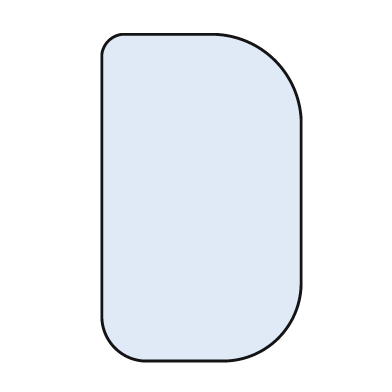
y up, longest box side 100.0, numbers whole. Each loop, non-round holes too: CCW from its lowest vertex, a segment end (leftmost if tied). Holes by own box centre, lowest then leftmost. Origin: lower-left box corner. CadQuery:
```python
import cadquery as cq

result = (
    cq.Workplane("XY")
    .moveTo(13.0, 0.0)
    .lineTo(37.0, 0.0)
    .threePointArc((54.0, 7.0), (61.0, 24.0))
    .lineTo(61.0, 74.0)
    .threePointArc((53.0, 92.0), (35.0, 100.0))
    .lineTo(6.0, 100.0)
    .threePointArc((2.0, 98.0), (0.0, 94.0))
    .lineTo(0.0, 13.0)
    .threePointArc((4.0, 4.0), (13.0, 0.0))
    .close()
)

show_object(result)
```